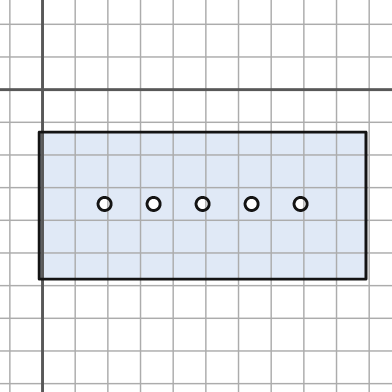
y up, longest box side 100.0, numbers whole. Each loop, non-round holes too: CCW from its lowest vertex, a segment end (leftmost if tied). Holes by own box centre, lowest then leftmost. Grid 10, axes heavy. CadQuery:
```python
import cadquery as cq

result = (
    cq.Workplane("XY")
    .moveTo(-1.0, -58.0)
    .lineTo(99.0, -58.0)
    .lineTo(99.0, -13.0)
    .lineTo(-1.0, -13.0)
    .close()
    .moveTo(19.0, -35.0)
    .circle(2.0)
    .moveTo(34.0, -35.0)
    .circle(2.0)
    .moveTo(49.0, -35.0)
    .circle(2.0)
    .moveTo(64.0, -35.0)
    .circle(2.0)
    .moveTo(79.0, -35.0)
    .circle(2.0)
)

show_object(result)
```